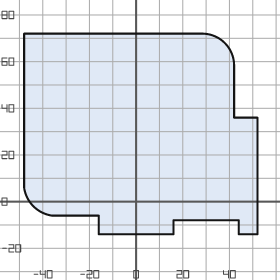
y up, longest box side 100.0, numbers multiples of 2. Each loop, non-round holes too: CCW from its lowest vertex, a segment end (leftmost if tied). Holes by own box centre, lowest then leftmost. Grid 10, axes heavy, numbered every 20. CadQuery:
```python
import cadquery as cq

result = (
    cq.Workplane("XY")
    .moveTo(-16.0, -14.0)
    .lineTo(16.0, -14.0)
    .lineTo(16.0, -8.0)
    .lineTo(44.0, -8.0)
    .lineTo(44.0, -14.0)
    .lineTo(52.0, -14.0)
    .lineTo(52.0, 36.0)
    .lineTo(42.0, 36.0)
    .lineTo(42.0, 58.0)
    .threePointArc((38.0, 68.0), (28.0, 72.0))
    .lineTo(-48.0, 72.0)
    .lineTo(-48.0, 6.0)
    .threePointArc((-44.0, -2.0), (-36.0, -6.0))
    .lineTo(-16.0, -6.0)
    .close()
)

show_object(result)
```